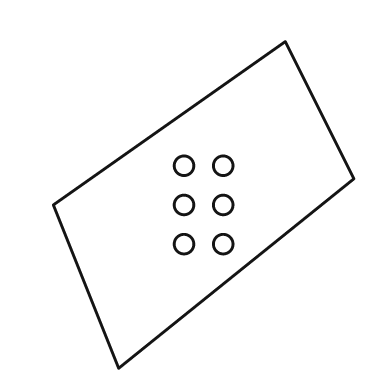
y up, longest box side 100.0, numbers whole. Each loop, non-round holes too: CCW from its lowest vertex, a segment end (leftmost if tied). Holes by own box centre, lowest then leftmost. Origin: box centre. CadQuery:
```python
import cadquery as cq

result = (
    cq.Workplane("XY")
    .moveTo(-26.0, -50.0)
    .lineTo(46.0, 8.0)
    .lineTo(25.0, 50.0)
    .lineTo(-46.0, 0.0)
    .close()
    .moveTo(-6.0, -12.0)
    .circle(3.0)
    .moveTo(6.0, -12.0)
    .circle(3.0)
    .moveTo(-6.0, 0.0)
    .circle(3.0)
    .moveTo(6.0, 0.0)
    .circle(3.0)
    .moveTo(-6.0, 12.0)
    .circle(3.0)
    .moveTo(6.0, 12.0)
    .circle(3.0)
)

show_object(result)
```